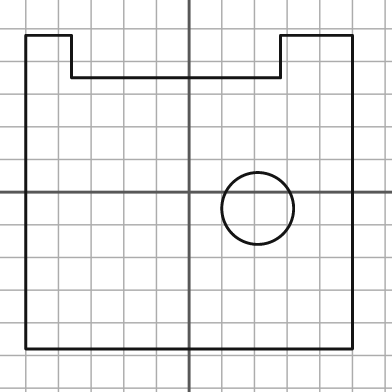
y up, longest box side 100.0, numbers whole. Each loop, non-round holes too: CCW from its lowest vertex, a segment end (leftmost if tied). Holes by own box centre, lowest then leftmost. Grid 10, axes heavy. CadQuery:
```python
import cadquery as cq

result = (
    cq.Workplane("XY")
    .moveTo(-50.0, -48.0)
    .lineTo(50.0, -48.0)
    .lineTo(50.0, 48.0)
    .lineTo(28.0, 48.0)
    .lineTo(28.0, 35.0)
    .lineTo(-36.0, 35.0)
    .lineTo(-36.0, 48.0)
    .lineTo(-50.0, 48.0)
    .close()
    .moveTo(21.0, -5.0)
    .circle(11.0)
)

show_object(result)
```